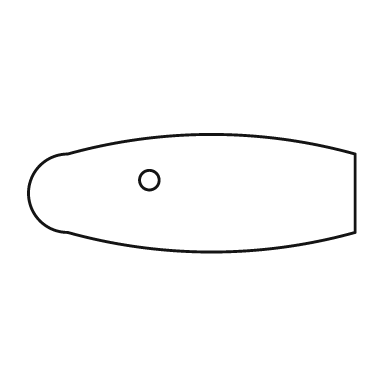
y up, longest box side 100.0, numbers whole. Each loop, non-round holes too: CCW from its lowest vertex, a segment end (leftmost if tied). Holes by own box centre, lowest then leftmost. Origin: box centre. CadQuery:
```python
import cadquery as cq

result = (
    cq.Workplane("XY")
    .moveTo(-38.0, -12.0)
    .threePointArc((6.0, -18.0), (50.0, -12.0))
    .lineTo(50.0, 12.0)
    .threePointArc((6.0, 18.0), (-38.0, 12.0))
    .threePointArc((-50.0, 0.0), (-38.0, -12.0))
    .close()
    .moveTo(-13.0, 4.0)
    .circle(3.0)
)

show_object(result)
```